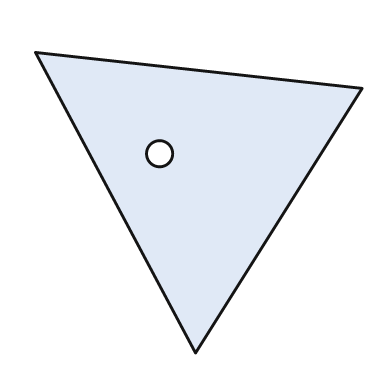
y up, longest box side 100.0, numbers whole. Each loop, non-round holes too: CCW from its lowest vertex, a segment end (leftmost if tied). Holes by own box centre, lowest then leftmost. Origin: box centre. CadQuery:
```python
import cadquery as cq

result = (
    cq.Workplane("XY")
    .moveTo(-1.0, -46.0)
    .lineTo(50.0, 35.0)
    .lineTo(-50.0, 46.0)
    .close()
    .moveTo(-12.0, 15.0)
    .circle(4.0)
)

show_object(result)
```